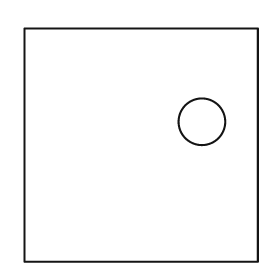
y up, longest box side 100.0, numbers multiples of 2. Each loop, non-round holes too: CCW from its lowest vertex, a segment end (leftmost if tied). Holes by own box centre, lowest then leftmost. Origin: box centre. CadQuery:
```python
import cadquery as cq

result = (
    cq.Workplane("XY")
    .moveTo(-50.0, -50.0)
    .lineTo(50.0, -50.0)
    .lineTo(50.0, 50.0)
    .lineTo(-50.0, 50.0)
    .close()
    .moveTo(26.0, 10.0)
    .circle(10.0)
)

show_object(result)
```